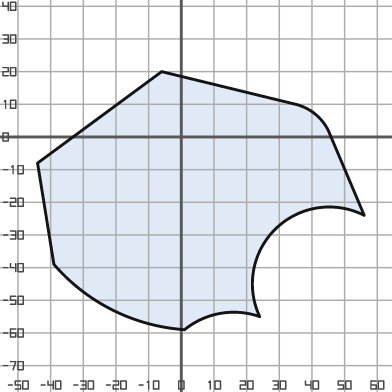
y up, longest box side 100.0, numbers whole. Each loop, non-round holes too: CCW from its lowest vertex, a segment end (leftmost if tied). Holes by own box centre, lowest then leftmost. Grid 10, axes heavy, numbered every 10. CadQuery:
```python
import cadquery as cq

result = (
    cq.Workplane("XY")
    .moveTo(1.0, -59.0)
    .threePointArc((12.0, -54.0), (24.0, -55.0))
    .threePointArc((29.0, -28.0), (56.0, -24.0))
    .lineTo(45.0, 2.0)
    .threePointArc((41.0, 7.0), (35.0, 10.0))
    .lineTo(-6.0, 20.0)
    .lineTo(-44.0, -8.0)
    .lineTo(-39.0, -39.0)
    .threePointArc((-21.0, -53.0), (1.0, -59.0))
    .close()
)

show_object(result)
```